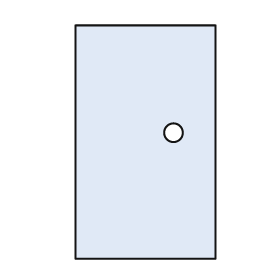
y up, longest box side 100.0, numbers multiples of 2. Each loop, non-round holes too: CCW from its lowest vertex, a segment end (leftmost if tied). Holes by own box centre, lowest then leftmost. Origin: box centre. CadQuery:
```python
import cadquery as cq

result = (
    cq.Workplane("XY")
    .moveTo(-30.0, -50.0)
    .lineTo(30.0, -50.0)
    .lineTo(30.0, 50.0)
    .lineTo(-30.0, 50.0)
    .close()
    .moveTo(12.0, 4.0)
    .circle(4.0)
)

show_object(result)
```